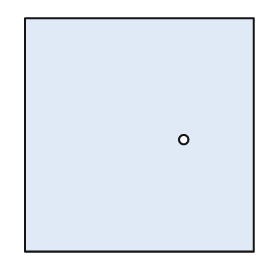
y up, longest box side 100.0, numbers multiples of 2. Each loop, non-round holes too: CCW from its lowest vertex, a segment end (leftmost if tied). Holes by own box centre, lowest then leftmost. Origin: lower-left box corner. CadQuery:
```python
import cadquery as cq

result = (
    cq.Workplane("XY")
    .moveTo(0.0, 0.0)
    .lineTo(98.0, 0.0)
    .lineTo(98.0, 100.0)
    .lineTo(0.0, 100.0)
    .close()
    .moveTo(68.0, 48.0)
    .circle(2.0)
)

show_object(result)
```